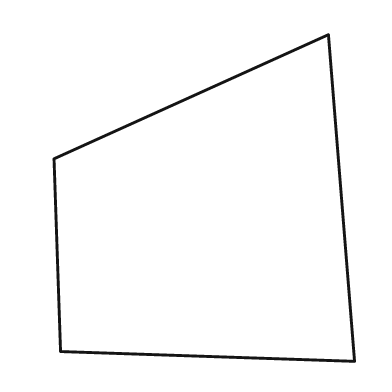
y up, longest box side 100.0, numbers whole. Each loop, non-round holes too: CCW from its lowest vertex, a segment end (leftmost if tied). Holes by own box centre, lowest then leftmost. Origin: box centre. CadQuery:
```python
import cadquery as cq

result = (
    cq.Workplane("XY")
    .moveTo(46.0, -50.0)
    .lineTo(38.0, 50.0)
    .lineTo(-46.0, 12.0)
    .lineTo(-44.0, -47.0)
    .close()
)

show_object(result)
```